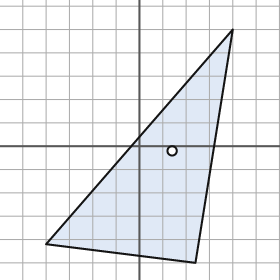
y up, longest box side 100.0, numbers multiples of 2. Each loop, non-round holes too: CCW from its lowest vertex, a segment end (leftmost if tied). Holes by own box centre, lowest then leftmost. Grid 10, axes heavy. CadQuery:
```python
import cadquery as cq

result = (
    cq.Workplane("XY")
    .moveTo(24.0, -50.0)
    .lineTo(40.0, 50.0)
    .lineTo(-40.0, -42.0)
    .close()
    .moveTo(14.0, -2.0)
    .circle(2.0)
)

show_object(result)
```